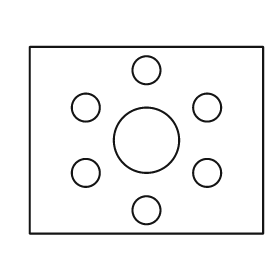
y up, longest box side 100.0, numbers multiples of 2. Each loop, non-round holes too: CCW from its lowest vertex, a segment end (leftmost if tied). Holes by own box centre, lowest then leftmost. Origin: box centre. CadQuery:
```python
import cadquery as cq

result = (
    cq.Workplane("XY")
    .moveTo(-50.0, -40.0)
    .lineTo(50.0, -40.0)
    .lineTo(50.0, 40.0)
    .lineTo(-50.0, 40.0)
    .close()
    .moveTo(0.0, -30.0)
    .circle(6.0)
    .moveTo(-26.0, -14.0)
    .circle(6.0)
    .moveTo(26.0, -14.0)
    .circle(6.0)
    .moveTo(0.0, 0.0)
    .circle(14.0)
    .moveTo(-26.0, 14.0)
    .circle(6.0)
    .moveTo(26.0, 14.0)
    .circle(6.0)
    .moveTo(0.0, 30.0)
    .circle(6.0)
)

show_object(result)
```